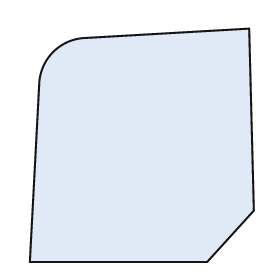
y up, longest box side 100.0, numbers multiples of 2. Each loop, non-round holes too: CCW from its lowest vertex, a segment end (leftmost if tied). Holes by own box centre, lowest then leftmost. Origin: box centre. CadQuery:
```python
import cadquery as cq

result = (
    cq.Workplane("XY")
    .moveTo(-48.0, -50.0)
    .lineTo(28.0, -50.0)
    .lineTo(48.0, -28.0)
    .lineTo(46.0, 50.0)
    .lineTo(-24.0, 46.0)
    .threePointArc((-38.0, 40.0), (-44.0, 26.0))
    .close()
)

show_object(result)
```